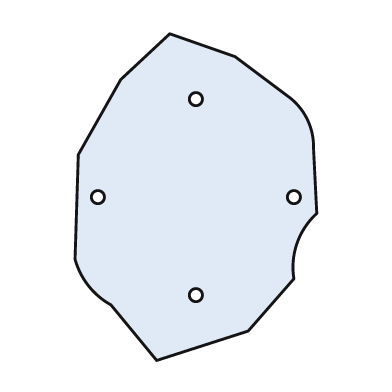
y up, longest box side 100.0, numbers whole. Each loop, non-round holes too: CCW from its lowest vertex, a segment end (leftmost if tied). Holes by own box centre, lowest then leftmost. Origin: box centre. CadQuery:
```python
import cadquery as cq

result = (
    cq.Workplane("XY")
    .moveTo(-12.0, -50.0)
    .lineTo(16.0, -41.0)
    .lineTo(30.0, -25.0)
    .threePointArc((31.0, -14.0), (37.0, -5.0))
    .lineTo(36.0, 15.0)
    .threePointArc((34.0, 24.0), (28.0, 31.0))
    .lineTo(12.0, 43.0)
    .lineTo(-8.0, 50.0)
    .lineTo(-23.0, 36.0)
    .lineTo(-36.0, 13.0)
    .lineTo(-37.0, -19.0)
    .threePointArc((-33.0, -27.0), (-26.0, -33.0))
    .close()
    .moveTo(0.0, -30.0)
    .circle(2.0)
    .moveTo(-30.0, 0.0)
    .circle(2.0)
    .moveTo(30.0, 0.0)
    .circle(2.0)
    .moveTo(0.0, 30.0)
    .circle(2.0)
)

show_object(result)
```